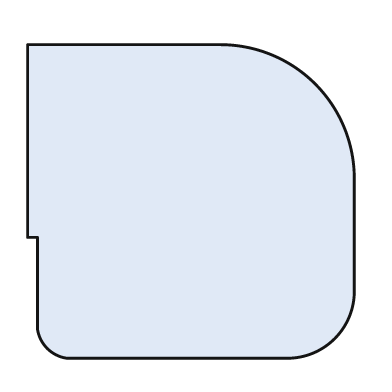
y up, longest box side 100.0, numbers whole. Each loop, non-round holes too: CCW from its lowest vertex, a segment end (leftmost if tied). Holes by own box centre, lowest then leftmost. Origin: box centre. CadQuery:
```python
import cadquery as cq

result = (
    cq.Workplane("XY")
    .moveTo(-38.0, -48.0)
    .lineTo(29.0, -48.0)
    .threePointArc((44.0, -42.0), (50.0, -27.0))
    .lineTo(50.0, 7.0)
    .threePointArc((38.0, 36.0), (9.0, 48.0))
    .lineTo(-50.0, 48.0)
    .lineTo(-50.0, -11.0)
    .lineTo(-47.0, -11.0)
    .lineTo(-47.0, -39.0)
    .threePointArc((-44.0, -45.0), (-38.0, -48.0))
    .close()
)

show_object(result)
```